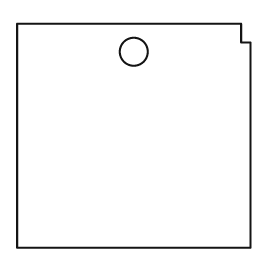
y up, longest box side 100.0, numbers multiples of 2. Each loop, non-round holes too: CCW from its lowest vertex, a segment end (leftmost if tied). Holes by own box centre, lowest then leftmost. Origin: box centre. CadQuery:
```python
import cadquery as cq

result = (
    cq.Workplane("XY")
    .moveTo(-50.0, -48.0)
    .lineTo(50.0, -48.0)
    .lineTo(50.0, 40.0)
    .lineTo(46.0, 40.0)
    .lineTo(46.0, 48.0)
    .lineTo(-50.0, 48.0)
    .close()
    .moveTo(0.0, 36.0)
    .circle(6.0)
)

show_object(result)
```